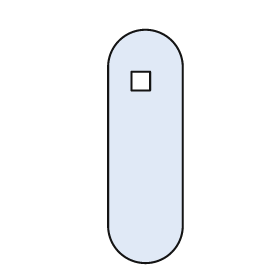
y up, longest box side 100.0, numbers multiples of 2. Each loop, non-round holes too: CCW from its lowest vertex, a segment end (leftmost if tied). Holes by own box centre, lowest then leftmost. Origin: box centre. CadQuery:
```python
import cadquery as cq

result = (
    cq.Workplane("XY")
    .moveTo(-16.0, -34.0)
    .threePointArc((0.0, -50.0), (16.0, -34.0))
    .lineTo(16.0, 34.0)
    .threePointArc((0.0, 50.0), (-16.0, 34.0))
    .close()
    .moveTo(-6.0, 24.0)
    .lineTo(2.0, 24.0)
    .lineTo(2.0, 32.0)
    .lineTo(-6.0, 32.0)
    .close()
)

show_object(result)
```